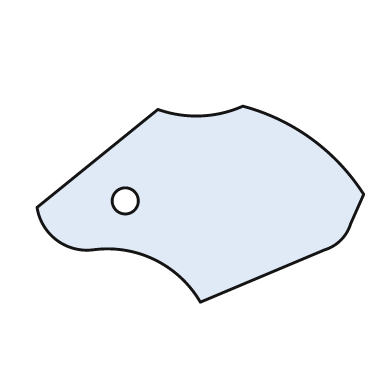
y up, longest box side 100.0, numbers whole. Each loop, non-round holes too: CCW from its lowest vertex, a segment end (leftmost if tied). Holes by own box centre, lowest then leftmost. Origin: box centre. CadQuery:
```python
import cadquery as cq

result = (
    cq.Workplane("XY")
    .moveTo(0.0, -30.0)
    .lineTo(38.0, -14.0)
    .threePointArc((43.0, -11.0), (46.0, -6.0))
    .lineTo(50.0, 3.0)
    .threePointArc((34.0, 20.0), (13.0, 30.0))
    .threePointArc((0.0, 27.0), (-13.0, 29.0))
    .lineTo(-50.0, -1.0)
    .threePointArc((-44.0, -11.0), (-33.0, -14.0))
    .threePointArc((-14.0, -17.0), (0.0, -30.0))
    .close()
    .moveTo(-23.0, 1.0)
    .circle(4.0)
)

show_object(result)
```